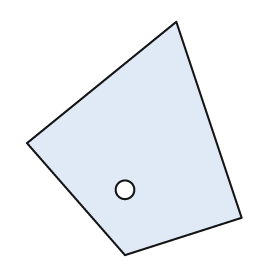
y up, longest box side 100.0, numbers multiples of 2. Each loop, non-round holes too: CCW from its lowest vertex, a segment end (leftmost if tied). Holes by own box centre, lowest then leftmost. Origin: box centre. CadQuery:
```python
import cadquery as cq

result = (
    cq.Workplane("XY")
    .moveTo(-4.0, -50.0)
    .lineTo(46.0, -34.0)
    .lineTo(18.0, 50.0)
    .lineTo(-46.0, -2.0)
    .close()
    .moveTo(-4.0, -22.0)
    .circle(4.0)
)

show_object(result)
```